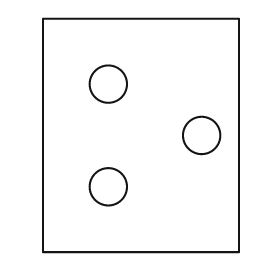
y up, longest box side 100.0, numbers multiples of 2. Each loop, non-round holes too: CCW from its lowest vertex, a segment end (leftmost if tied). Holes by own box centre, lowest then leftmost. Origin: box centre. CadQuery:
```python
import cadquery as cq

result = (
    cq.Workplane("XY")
    .moveTo(-42.0, -50.0)
    .lineTo(42.0, -50.0)
    .lineTo(42.0, 50.0)
    .lineTo(-42.0, 50.0)
    .close()
    .moveTo(-14.0, -22.0)
    .circle(8.0)
    .moveTo(26.0, 0.0)
    .circle(8.0)
    .moveTo(-14.0, 22.0)
    .circle(8.0)
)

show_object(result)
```